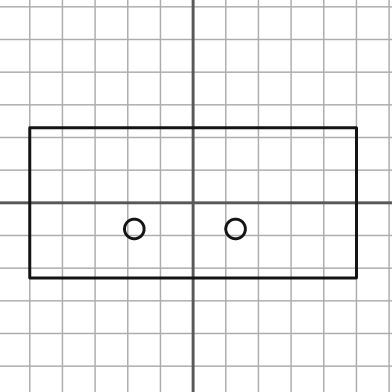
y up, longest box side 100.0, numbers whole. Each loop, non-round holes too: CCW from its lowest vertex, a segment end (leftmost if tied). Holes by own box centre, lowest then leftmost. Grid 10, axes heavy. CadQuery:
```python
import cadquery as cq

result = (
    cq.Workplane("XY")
    .moveTo(-50.0, -23.0)
    .lineTo(50.0, -23.0)
    .lineTo(50.0, 23.0)
    .lineTo(-50.0, 23.0)
    .close()
    .moveTo(-18.0, -8.0)
    .circle(3.0)
    .moveTo(13.0, -8.0)
    .circle(3.0)
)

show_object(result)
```